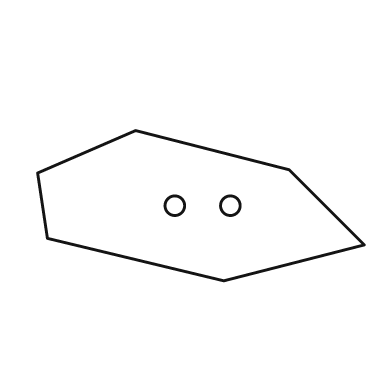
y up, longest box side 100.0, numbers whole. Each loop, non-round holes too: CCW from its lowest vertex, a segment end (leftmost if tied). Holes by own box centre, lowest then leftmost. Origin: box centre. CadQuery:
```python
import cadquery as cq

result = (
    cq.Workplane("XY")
    .moveTo(7.0, -23.0)
    .lineTo(50.0, -12.0)
    .lineTo(27.0, 11.0)
    .lineTo(-20.0, 23.0)
    .lineTo(-50.0, 10.0)
    .lineTo(-47.0, -10.0)
    .close()
    .moveTo(-8.0, 0.0)
    .circle(3.0)
    .moveTo(9.0, 0.0)
    .circle(3.0)
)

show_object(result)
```